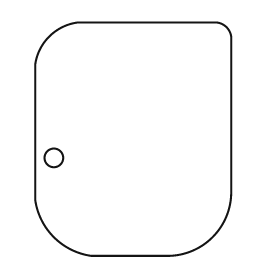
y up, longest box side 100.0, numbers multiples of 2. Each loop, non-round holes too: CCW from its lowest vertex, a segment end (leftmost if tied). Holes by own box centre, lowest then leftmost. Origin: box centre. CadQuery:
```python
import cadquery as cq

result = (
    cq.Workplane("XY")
    .moveTo(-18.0, -50.0)
    .lineTo(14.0, -50.0)
    .threePointArc((34.0, -42.0), (42.0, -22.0))
    .lineTo(42.0, 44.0)
    .threePointArc((40.0, 48.0), (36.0, 50.0))
    .lineTo(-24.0, 50.0)
    .threePointArc((-36.0, 44.0), (-42.0, 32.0))
    .lineTo(-42.0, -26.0)
    .threePointArc((-34.0, -42.0), (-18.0, -50.0))
    .close()
    .moveTo(-34.0, -8.0)
    .circle(4.0)
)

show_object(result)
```